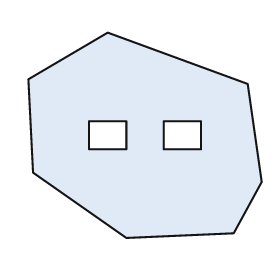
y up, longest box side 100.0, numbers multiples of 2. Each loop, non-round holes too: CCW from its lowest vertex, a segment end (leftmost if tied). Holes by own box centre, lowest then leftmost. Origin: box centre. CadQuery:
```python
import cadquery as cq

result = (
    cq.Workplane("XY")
    .moveTo(-8.0, -44.0)
    .lineTo(38.0, -42.0)
    .lineTo(50.0, -20.0)
    .lineTo(44.0, 22.0)
    .lineTo(-16.0, 44.0)
    .lineTo(-50.0, 24.0)
    .lineTo(-48.0, -16.0)
    .close()
    .moveTo(-24.0, -6.0)
    .lineTo(-8.0, -6.0)
    .lineTo(-8.0, 6.0)
    .lineTo(-24.0, 6.0)
    .close()
    .moveTo(8.0, -6.0)
    .lineTo(24.0, -6.0)
    .lineTo(24.0, 6.0)
    .lineTo(8.0, 6.0)
    .close()
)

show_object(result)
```